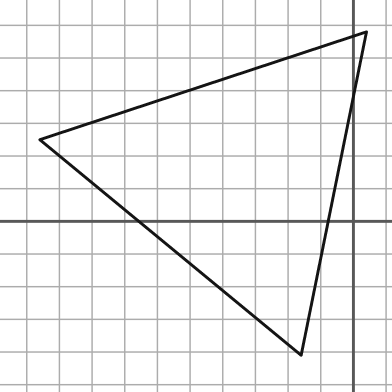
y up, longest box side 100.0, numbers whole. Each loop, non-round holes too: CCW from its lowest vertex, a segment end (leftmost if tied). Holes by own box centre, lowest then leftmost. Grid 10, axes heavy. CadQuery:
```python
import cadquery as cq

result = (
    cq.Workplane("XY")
    .moveTo(-16.0, -41.0)
    .lineTo(4.0, 58.0)
    .lineTo(-96.0, 25.0)
    .close()
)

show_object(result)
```